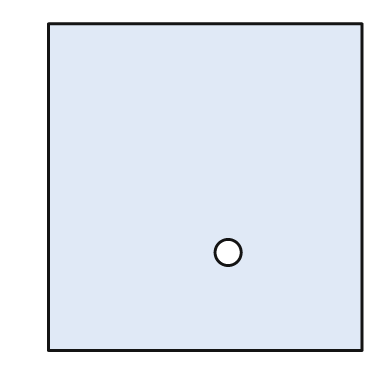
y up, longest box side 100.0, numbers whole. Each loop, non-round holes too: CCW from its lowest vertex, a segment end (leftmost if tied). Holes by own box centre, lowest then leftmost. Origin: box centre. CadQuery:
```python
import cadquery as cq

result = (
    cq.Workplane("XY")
    .moveTo(-48.0, -50.0)
    .lineTo(48.0, -50.0)
    .lineTo(48.0, 50.0)
    .lineTo(-48.0, 50.0)
    .close()
    .moveTo(7.0, -20.0)
    .circle(4.0)
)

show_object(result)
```